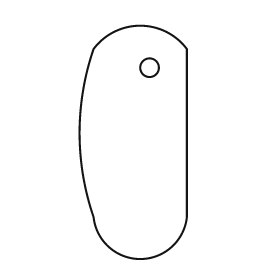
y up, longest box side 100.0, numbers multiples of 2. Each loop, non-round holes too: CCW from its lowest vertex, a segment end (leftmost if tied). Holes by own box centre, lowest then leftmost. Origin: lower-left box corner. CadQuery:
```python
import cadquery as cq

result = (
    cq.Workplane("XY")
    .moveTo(6.0, 18.0)
    .threePointArc((26.0, 0.0), (46.0, 18.0))
    .lineTo(46.0, 90.0)
    .threePointArc((26.0, 100.0), (6.0, 90.0))
    .threePointArc((0.0, 54.0), (6.0, 18.0))
    .close()
    .moveTo(30.0, 82.0)
    .circle(4.0)
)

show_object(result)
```